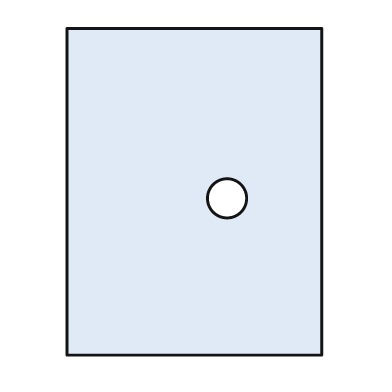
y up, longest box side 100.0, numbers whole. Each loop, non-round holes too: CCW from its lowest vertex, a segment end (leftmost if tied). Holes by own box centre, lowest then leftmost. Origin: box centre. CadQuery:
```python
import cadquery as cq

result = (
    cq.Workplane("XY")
    .moveTo(-39.0, -50.0)
    .lineTo(39.0, -50.0)
    .lineTo(39.0, 50.0)
    .lineTo(-39.0, 50.0)
    .close()
    .moveTo(10.0, -2.0)
    .circle(6.0)
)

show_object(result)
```